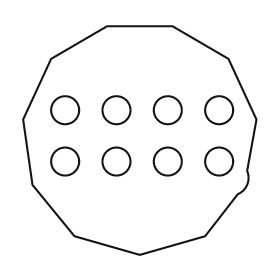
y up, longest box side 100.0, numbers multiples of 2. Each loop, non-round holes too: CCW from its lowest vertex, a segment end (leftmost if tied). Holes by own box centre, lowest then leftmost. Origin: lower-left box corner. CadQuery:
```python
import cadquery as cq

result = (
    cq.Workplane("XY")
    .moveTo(50.0, 0.0)
    .lineTo(78.0, 8.0)
    .lineTo(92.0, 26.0)
    .threePointArc((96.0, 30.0), (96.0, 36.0))
    .lineTo(100.0, 58.0)
    .lineTo(88.0, 84.0)
    .lineTo(64.0, 98.0)
    .lineTo(36.0, 98.0)
    .lineTo(12.0, 84.0)
    .lineTo(0.0, 58.0)
    .lineTo(4.0, 30.0)
    .lineTo(22.0, 8.0)
    .close()
    .moveTo(18.0, 40.0)
    .circle(6.0)
    .moveTo(40.0, 40.0)
    .circle(6.0)
    .moveTo(62.0, 40.0)
    .circle(6.0)
    .moveTo(84.0, 40.0)
    .circle(6.0)
    .moveTo(18.0, 62.0)
    .circle(6.0)
    .moveTo(40.0, 62.0)
    .circle(6.0)
    .moveTo(62.0, 62.0)
    .circle(6.0)
    .moveTo(84.0, 62.0)
    .circle(6.0)
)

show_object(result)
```